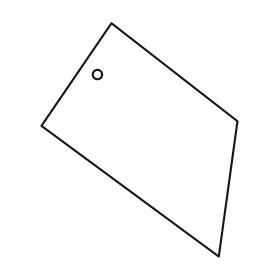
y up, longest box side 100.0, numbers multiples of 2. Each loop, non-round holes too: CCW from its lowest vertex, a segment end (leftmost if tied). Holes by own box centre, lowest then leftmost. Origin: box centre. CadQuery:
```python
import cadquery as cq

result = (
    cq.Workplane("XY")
    .moveTo(34.0, -50.0)
    .lineTo(42.0, 8.0)
    .lineTo(-12.0, 50.0)
    .lineTo(-42.0, 6.0)
    .close()
    .moveTo(-18.0, 28.0)
    .circle(2.0)
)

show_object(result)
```